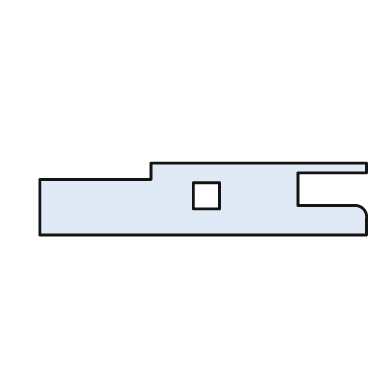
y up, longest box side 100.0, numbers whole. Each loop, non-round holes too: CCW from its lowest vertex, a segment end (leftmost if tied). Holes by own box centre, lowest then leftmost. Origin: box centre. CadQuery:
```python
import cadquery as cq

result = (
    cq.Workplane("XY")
    .moveTo(-50.0, -11.0)
    .lineTo(50.0, -11.0)
    .lineTo(50.0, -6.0)
    .threePointArc((49.0, -3.0), (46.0, -2.0))
    .lineTo(29.0, -2.0)
    .lineTo(29.0, 8.0)
    .lineTo(50.0, 8.0)
    .lineTo(50.0, 11.0)
    .lineTo(-16.0, 11.0)
    .lineTo(-16.0, 6.0)
    .lineTo(-50.0, 6.0)
    .close()
    .moveTo(-3.0, -3.0)
    .lineTo(5.0, -3.0)
    .lineTo(5.0, 5.0)
    .lineTo(-3.0, 5.0)
    .close()
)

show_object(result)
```